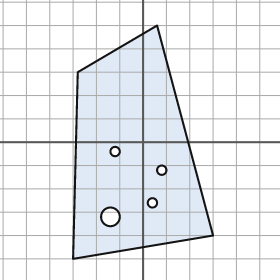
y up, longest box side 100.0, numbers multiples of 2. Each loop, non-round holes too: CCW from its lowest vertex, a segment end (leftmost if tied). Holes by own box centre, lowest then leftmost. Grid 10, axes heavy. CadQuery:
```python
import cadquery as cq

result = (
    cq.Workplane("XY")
    .moveTo(-30.0, -50.0)
    .lineTo(30.0, -40.0)
    .lineTo(6.0, 50.0)
    .lineTo(-28.0, 30.0)
    .close()
    .moveTo(-14.0, -32.0)
    .circle(4.0)
    .moveTo(4.0, -26.0)
    .circle(2.0)
    .moveTo(8.0, -12.0)
    .circle(2.0)
    .moveTo(-12.0, -4.0)
    .circle(2.0)
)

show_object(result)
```